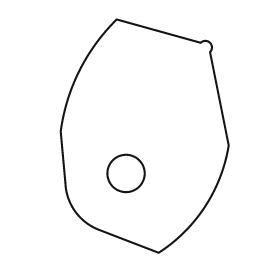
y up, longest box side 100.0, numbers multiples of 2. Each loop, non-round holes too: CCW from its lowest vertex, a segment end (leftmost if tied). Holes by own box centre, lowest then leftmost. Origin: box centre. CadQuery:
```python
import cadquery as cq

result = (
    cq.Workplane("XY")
    .moveTo(6.0, -50.0)
    .threePointArc((26.0, -30.0), (36.0, -4.0))
    .lineTo(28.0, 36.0)
    .threePointArc((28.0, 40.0), (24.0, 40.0))
    .lineTo(-12.0, 50.0)
    .threePointArc((-28.0, 28.0), (-36.0, 2.0))
    .lineTo(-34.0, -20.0)
    .threePointArc((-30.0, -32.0), (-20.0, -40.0))
    .close()
    .moveTo(-8.0, -16.0)
    .circle(8.0)
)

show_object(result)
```